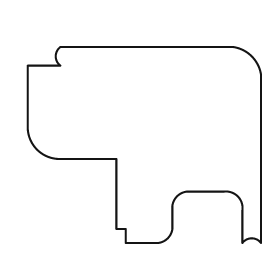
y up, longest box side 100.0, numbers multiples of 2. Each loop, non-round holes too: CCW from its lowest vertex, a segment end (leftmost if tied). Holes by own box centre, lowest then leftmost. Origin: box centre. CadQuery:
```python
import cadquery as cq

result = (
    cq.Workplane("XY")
    .moveTo(-8.0, -42.0)
    .lineTo(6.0, -42.0)
    .threePointArc((10.0, -40.0), (12.0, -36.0))
    .lineTo(12.0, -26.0)
    .threePointArc((14.0, -22.0), (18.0, -20.0))
    .lineTo(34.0, -20.0)
    .threePointArc((40.0, -22.0), (42.0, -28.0))
    .lineTo(42.0, -42.0)
    .threePointArc((46.0, -40.0), (50.0, -42.0))
    .lineTo(50.0, 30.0)
    .threePointArc((46.0, 38.0), (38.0, 42.0))
    .lineTo(-36.0, 42.0)
    .threePointArc((-38.0, 38.0), (-36.0, 34.0))
    .lineTo(-50.0, 34.0)
    .lineTo(-50.0, 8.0)
    .threePointArc((-46.0, -2.0), (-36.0, -6.0))
    .lineTo(-12.0, -6.0)
    .lineTo(-12.0, -36.0)
    .lineTo(-8.0, -36.0)
    .close()
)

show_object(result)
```